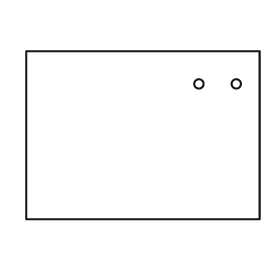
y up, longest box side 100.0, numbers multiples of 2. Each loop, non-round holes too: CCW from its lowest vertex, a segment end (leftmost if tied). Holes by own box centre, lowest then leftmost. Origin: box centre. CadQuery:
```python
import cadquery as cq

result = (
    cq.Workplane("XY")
    .moveTo(-50.0, -36.0)
    .lineTo(50.0, -36.0)
    .lineTo(50.0, 36.0)
    .lineTo(-50.0, 36.0)
    .close()
    .moveTo(24.0, 22.0)
    .circle(2.0)
    .moveTo(40.0, 22.0)
    .circle(2.0)
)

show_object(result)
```